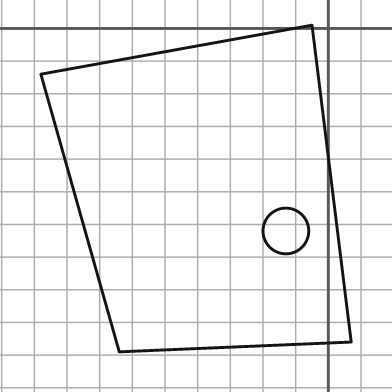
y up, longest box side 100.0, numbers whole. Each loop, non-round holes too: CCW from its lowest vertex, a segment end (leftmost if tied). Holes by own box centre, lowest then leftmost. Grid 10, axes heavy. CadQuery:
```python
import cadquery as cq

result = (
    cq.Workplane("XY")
    .moveTo(-64.0, -99.0)
    .lineTo(7.0, -96.0)
    .lineTo(-5.0, 1.0)
    .lineTo(-88.0, -14.0)
    .close()
    .moveTo(-13.0, -62.0)
    .circle(7.0)
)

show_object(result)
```